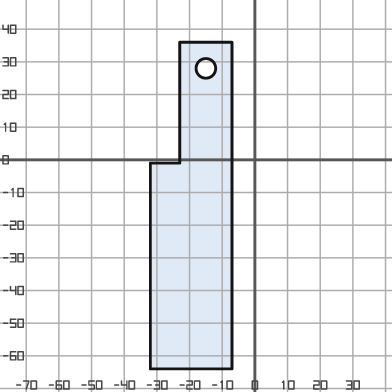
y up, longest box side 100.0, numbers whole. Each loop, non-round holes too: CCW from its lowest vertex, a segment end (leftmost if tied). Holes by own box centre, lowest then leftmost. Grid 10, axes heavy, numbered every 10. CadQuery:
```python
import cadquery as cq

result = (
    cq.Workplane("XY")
    .moveTo(-32.0, -64.0)
    .lineTo(-7.0, -64.0)
    .lineTo(-7.0, 36.0)
    .lineTo(-23.0, 36.0)
    .lineTo(-23.0, -1.0)
    .lineTo(-32.0, -1.0)
    .close()
    .moveTo(-15.0, 28.0)
    .circle(3.0)
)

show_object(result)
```